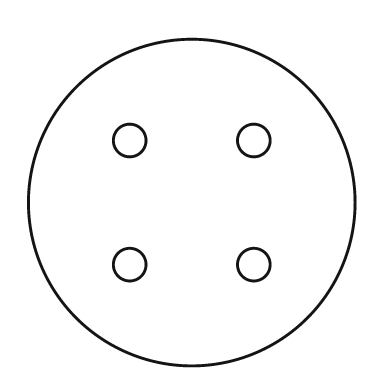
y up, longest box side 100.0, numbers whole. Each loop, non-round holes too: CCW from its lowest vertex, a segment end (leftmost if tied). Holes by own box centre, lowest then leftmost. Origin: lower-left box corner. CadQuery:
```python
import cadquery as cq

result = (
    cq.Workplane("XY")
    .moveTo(50.0, 50.0)
    .circle(50.0)
    .moveTo(31.0, 31.0)
    .circle(5.0)
    .moveTo(69.0, 31.0)
    .circle(5.0)
    .moveTo(31.0, 69.0)
    .circle(5.0)
    .moveTo(69.0, 69.0)
    .circle(5.0)
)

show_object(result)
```